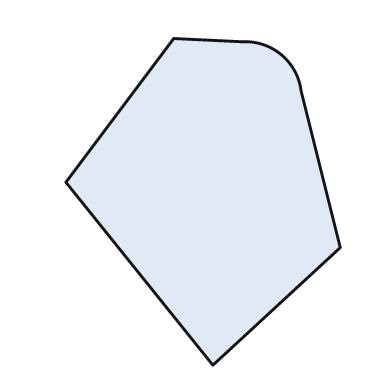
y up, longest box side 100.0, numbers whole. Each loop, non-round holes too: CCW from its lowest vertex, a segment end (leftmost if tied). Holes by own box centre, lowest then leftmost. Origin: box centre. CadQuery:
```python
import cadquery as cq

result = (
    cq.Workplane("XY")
    .moveTo(3.0, -50.0)
    .lineTo(42.0, -14.0)
    .lineTo(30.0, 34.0)
    .threePointArc((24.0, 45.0), (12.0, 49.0))
    .lineTo(-9.0, 50.0)
    .lineTo(-42.0, 6.0)
    .close()
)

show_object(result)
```